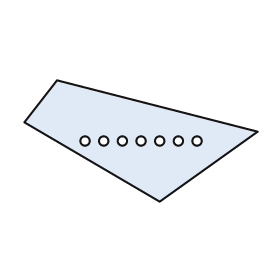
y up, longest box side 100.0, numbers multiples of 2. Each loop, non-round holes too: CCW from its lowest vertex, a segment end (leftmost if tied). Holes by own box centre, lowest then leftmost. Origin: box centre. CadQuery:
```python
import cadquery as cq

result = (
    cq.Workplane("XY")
    .moveTo(8.0, -26.0)
    .lineTo(50.0, 4.0)
    .lineTo(-36.0, 26.0)
    .lineTo(-50.0, 8.0)
    .close()
    .moveTo(-24.0, 0.0)
    .circle(2.0)
    .moveTo(-16.0, 0.0)
    .circle(2.0)
    .moveTo(-8.0, 0.0)
    .circle(2.0)
    .moveTo(0.0, 0.0)
    .circle(2.0)
    .moveTo(8.0, 0.0)
    .circle(2.0)
    .moveTo(16.0, 0.0)
    .circle(2.0)
    .moveTo(24.0, 0.0)
    .circle(2.0)
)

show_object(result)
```